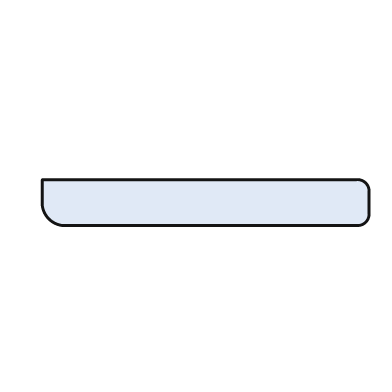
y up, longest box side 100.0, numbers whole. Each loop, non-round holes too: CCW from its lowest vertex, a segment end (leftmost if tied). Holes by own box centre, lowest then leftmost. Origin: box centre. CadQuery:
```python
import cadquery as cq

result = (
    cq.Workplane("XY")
    .moveTo(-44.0, -7.0)
    .lineTo(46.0, -7.0)
    .threePointArc((49.0, -6.0), (50.0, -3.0))
    .lineTo(50.0, 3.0)
    .threePointArc((49.0, 6.0), (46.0, 7.0))
    .lineTo(-50.0, 7.0)
    .lineTo(-50.0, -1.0)
    .threePointArc((-48.0, -5.0), (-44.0, -7.0))
    .close()
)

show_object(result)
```